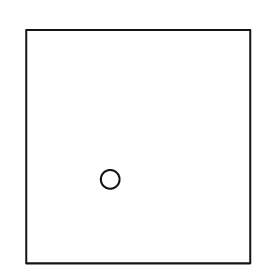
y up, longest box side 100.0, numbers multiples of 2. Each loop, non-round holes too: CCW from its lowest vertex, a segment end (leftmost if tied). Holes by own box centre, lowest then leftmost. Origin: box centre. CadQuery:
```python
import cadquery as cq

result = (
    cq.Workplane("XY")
    .moveTo(-48.0, -50.0)
    .lineTo(48.0, -50.0)
    .lineTo(48.0, 50.0)
    .lineTo(-48.0, 50.0)
    .close()
    .moveTo(-12.0, -14.0)
    .circle(4.0)
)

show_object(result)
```